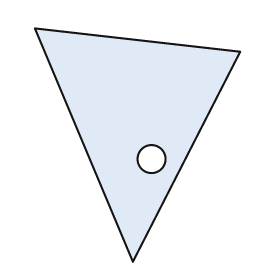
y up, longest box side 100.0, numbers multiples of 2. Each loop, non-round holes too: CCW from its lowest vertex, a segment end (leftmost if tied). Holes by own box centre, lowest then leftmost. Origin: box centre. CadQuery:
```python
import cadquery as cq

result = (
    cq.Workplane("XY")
    .moveTo(-2.0, -50.0)
    .lineTo(44.0, 40.0)
    .lineTo(-44.0, 50.0)
    .close()
    .moveTo(6.0, -6.0)
    .circle(6.0)
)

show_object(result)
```